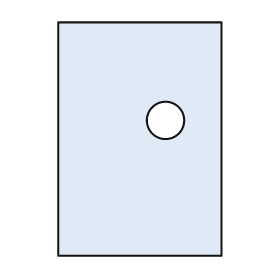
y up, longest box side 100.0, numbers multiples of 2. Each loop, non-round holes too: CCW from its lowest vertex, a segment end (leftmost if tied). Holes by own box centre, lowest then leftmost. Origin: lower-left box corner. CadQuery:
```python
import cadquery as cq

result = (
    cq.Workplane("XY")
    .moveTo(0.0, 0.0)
    .lineTo(70.0, 0.0)
    .lineTo(70.0, 100.0)
    .lineTo(0.0, 100.0)
    .close()
    .moveTo(46.0, 58.0)
    .circle(8.0)
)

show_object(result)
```